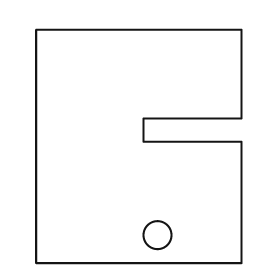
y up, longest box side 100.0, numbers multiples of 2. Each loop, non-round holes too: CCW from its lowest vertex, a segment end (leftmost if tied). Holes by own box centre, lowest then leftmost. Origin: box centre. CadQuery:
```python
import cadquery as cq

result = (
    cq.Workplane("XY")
    .moveTo(-44.0, -50.0)
    .lineTo(44.0, -50.0)
    .lineTo(44.0, 2.0)
    .lineTo(2.0, 2.0)
    .lineTo(2.0, 12.0)
    .lineTo(44.0, 12.0)
    .lineTo(44.0, 50.0)
    .lineTo(-44.0, 50.0)
    .close()
    .moveTo(8.0, -38.0)
    .circle(6.0)
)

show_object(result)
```